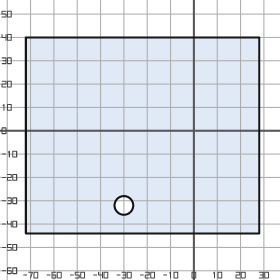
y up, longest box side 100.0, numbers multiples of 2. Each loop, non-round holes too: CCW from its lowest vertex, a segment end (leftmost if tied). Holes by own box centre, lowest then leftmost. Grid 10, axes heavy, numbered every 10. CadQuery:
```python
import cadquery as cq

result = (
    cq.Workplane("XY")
    .moveTo(-72.0, -44.0)
    .lineTo(28.0, -44.0)
    .lineTo(28.0, 40.0)
    .lineTo(-72.0, 40.0)
    .close()
    .moveTo(-30.0, -32.0)
    .circle(4.0)
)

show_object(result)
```